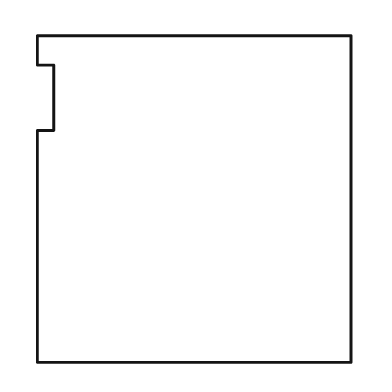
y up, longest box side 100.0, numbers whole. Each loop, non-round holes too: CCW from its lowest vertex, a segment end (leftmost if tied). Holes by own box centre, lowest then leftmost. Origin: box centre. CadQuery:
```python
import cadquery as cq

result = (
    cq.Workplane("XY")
    .moveTo(-48.0, -50.0)
    .lineTo(48.0, -50.0)
    .lineTo(48.0, 50.0)
    .lineTo(-48.0, 50.0)
    .lineTo(-48.0, 41.0)
    .lineTo(-43.0, 41.0)
    .lineTo(-43.0, 21.0)
    .lineTo(-48.0, 21.0)
    .close()
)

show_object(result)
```